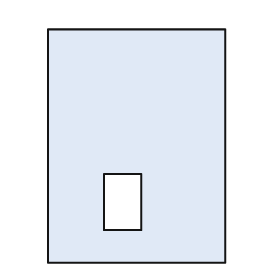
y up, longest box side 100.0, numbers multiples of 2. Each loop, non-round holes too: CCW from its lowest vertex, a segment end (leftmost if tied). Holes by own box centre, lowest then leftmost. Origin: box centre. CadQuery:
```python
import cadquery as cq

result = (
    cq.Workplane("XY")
    .moveTo(-38.0, -50.0)
    .lineTo(38.0, -50.0)
    .lineTo(38.0, 50.0)
    .lineTo(-38.0, 50.0)
    .close()
    .moveTo(-14.0, -36.0)
    .lineTo(2.0, -36.0)
    .lineTo(2.0, -12.0)
    .lineTo(-14.0, -12.0)
    .close()
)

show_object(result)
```